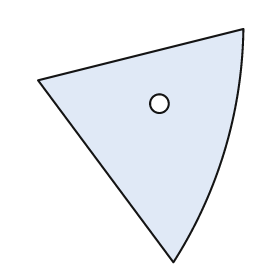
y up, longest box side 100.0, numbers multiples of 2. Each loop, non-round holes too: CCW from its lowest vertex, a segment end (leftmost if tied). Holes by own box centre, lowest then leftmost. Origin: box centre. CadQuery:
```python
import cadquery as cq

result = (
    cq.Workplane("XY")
    .moveTo(14.0, -50.0)
    .threePointArc((36.0, -2.0), (44.0, 50.0))
    .lineTo(-44.0, 28.0)
    .close()
    .moveTo(8.0, 18.0)
    .circle(4.0)
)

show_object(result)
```